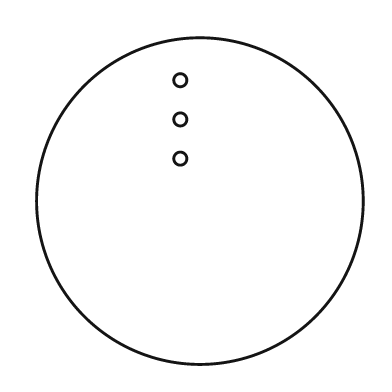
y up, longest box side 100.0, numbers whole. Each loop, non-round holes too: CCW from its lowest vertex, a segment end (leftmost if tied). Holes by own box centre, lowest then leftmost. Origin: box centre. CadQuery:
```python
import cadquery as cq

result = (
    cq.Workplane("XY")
    .moveTo(0.0, 0.0)
    .circle(50.0)
    .moveTo(-6.0, 13.0)
    .circle(2.0)
    .moveTo(-6.0, 25.0)
    .circle(2.0)
    .moveTo(-6.0, 37.0)
    .circle(2.0)
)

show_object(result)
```